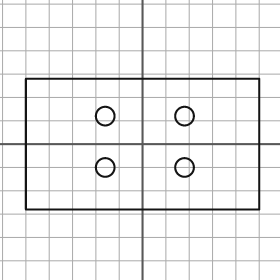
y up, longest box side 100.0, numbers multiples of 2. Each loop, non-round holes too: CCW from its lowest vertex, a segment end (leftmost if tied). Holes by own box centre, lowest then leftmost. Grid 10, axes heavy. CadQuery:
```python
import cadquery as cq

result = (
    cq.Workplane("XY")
    .moveTo(-50.0, -28.0)
    .lineTo(50.0, -28.0)
    .lineTo(50.0, 28.0)
    .lineTo(-50.0, 28.0)
    .close()
    .moveTo(-16.0, -10.0)
    .circle(4.0)
    .moveTo(18.0, -10.0)
    .circle(4.0)
    .moveTo(-16.0, 12.0)
    .circle(4.0)
    .moveTo(18.0, 12.0)
    .circle(4.0)
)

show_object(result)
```